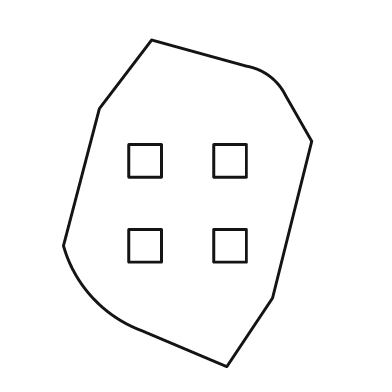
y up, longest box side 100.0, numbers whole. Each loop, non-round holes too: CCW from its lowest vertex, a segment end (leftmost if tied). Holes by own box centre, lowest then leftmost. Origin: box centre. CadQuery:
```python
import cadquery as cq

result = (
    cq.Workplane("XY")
    .moveTo(12.0, -50.0)
    .lineTo(26.0, -29.0)
    .lineTo(38.0, 19.0)
    .lineTo(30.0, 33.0)
    .threePointArc((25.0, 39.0), (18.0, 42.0))
    .lineTo(-11.0, 50.0)
    .lineTo(-27.0, 29.0)
    .lineTo(-38.0, -13.0)
    .threePointArc((-29.0, -29.0), (-14.0, -39.0))
    .close()
    .moveTo(-18.0, -18.0)
    .lineTo(-8.0, -18.0)
    .lineTo(-8.0, -8.0)
    .lineTo(-18.0, -8.0)
    .close()
    .moveTo(8.0, -18.0)
    .lineTo(18.0, -18.0)
    .lineTo(18.0, -8.0)
    .lineTo(8.0, -8.0)
    .close()
    .moveTo(-18.0, 8.0)
    .lineTo(-8.0, 8.0)
    .lineTo(-8.0, 18.0)
    .lineTo(-18.0, 18.0)
    .close()
    .moveTo(8.0, 8.0)
    .lineTo(18.0, 8.0)
    .lineTo(18.0, 18.0)
    .lineTo(8.0, 18.0)
    .close()
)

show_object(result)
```